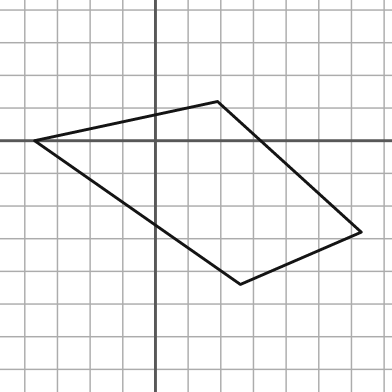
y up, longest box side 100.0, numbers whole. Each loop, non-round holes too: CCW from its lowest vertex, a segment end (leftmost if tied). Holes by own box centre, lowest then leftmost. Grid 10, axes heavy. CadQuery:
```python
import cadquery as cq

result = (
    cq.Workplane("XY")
    .moveTo(26.0, -44.0)
    .lineTo(63.0, -28.0)
    .lineTo(19.0, 12.0)
    .lineTo(-37.0, 0.0)
    .close()
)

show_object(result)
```